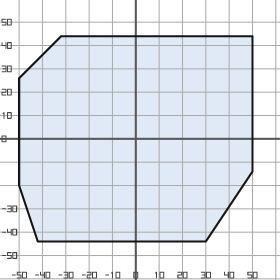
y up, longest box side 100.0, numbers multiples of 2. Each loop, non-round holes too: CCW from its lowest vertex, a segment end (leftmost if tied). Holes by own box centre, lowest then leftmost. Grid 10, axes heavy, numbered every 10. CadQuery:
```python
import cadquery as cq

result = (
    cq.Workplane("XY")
    .moveTo(-42.0, -44.0)
    .lineTo(30.0, -44.0)
    .lineTo(50.0, -14.0)
    .lineTo(50.0, 44.0)
    .lineTo(-32.0, 44.0)
    .lineTo(-50.0, 26.0)
    .lineTo(-50.0, -20.0)
    .close()
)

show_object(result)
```